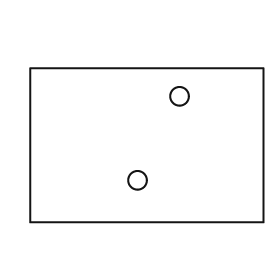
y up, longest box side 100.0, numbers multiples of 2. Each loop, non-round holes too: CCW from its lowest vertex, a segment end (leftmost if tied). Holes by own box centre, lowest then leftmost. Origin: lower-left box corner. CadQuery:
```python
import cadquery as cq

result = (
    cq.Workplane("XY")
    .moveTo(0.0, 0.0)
    .lineTo(100.0, 0.0)
    .lineTo(100.0, 66.0)
    .lineTo(0.0, 66.0)
    .close()
    .moveTo(46.0, 18.0)
    .circle(4.0)
    .moveTo(64.0, 54.0)
    .circle(4.0)
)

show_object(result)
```